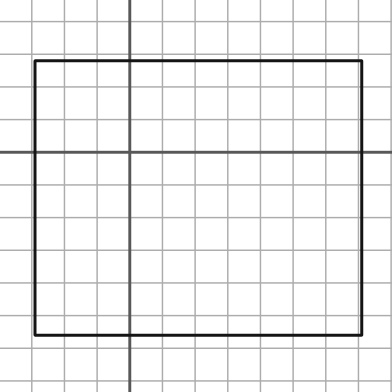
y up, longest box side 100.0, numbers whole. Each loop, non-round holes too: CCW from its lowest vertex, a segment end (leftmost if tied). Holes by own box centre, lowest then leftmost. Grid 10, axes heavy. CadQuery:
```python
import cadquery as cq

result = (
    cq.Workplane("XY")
    .moveTo(-29.0, -56.0)
    .lineTo(71.0, -56.0)
    .lineTo(71.0, 28.0)
    .lineTo(-29.0, 28.0)
    .close()
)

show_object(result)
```